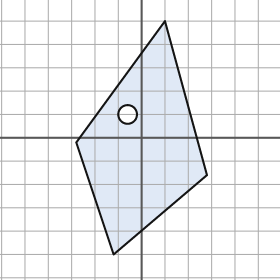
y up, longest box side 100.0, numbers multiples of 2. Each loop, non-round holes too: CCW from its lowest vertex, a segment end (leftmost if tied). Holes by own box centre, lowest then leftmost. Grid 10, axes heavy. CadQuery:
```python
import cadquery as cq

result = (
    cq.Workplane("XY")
    .moveTo(-12.0, -50.0)
    .lineTo(28.0, -16.0)
    .lineTo(10.0, 50.0)
    .lineTo(-28.0, -2.0)
    .close()
    .moveTo(-6.0, 10.0)
    .circle(4.0)
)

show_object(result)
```